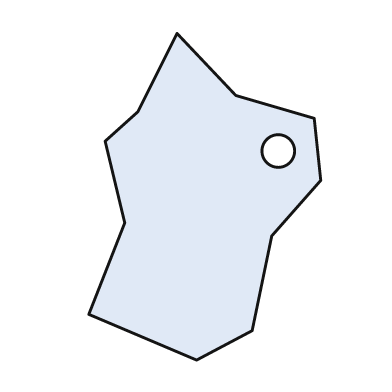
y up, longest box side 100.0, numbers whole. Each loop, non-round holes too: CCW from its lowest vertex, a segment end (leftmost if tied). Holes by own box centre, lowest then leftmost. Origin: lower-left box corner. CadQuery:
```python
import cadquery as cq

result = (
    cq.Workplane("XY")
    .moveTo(33.0, 0.0)
    .lineTo(50.0, 9.0)
    .lineTo(56.0, 38.0)
    .lineTo(71.0, 55.0)
    .lineTo(69.0, 74.0)
    .lineTo(45.0, 81.0)
    .lineTo(27.0, 100.0)
    .lineTo(15.0, 76.0)
    .lineTo(5.0, 67.0)
    .lineTo(11.0, 42.0)
    .lineTo(0.0, 14.0)
    .close()
    .moveTo(58.0, 64.0)
    .circle(5.0)
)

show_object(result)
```